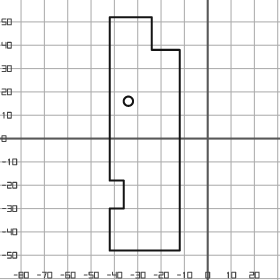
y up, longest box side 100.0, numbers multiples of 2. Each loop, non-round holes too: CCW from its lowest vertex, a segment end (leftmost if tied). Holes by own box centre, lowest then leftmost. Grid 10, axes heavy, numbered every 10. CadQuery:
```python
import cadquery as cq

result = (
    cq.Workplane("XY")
    .moveTo(-42.0, -48.0)
    .lineTo(-12.0, -48.0)
    .lineTo(-12.0, 38.0)
    .lineTo(-24.0, 38.0)
    .lineTo(-24.0, 52.0)
    .lineTo(-42.0, 52.0)
    .lineTo(-42.0, -18.0)
    .lineTo(-36.0, -18.0)
    .lineTo(-36.0, -30.0)
    .lineTo(-42.0, -30.0)
    .close()
    .moveTo(-34.0, 16.0)
    .circle(2.0)
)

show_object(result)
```